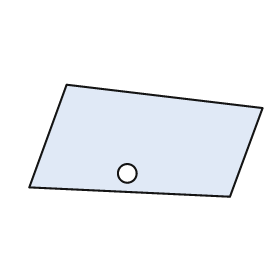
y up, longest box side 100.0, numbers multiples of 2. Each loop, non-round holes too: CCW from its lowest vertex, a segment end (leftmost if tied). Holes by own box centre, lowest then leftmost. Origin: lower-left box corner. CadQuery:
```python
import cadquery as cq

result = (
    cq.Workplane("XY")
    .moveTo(86.0, 0.0)
    .lineTo(100.0, 38.0)
    .lineTo(16.0, 48.0)
    .lineTo(0.0, 4.0)
    .close()
    .moveTo(42.0, 10.0)
    .circle(4.0)
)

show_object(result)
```